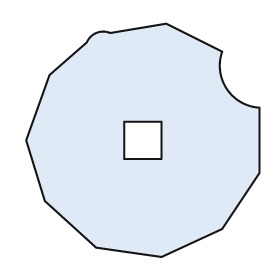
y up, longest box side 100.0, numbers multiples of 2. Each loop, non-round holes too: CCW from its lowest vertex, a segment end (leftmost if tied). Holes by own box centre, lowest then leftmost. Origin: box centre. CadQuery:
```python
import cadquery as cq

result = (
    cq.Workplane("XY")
    .moveTo(8.0, -50.0)
    .lineTo(34.0, -38.0)
    .lineTo(50.0, -14.0)
    .lineTo(50.0, 14.0)
    .threePointArc((36.0, 22.0), (34.0, 38.0))
    .lineTo(10.0, 50.0)
    .lineTo(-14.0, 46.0)
    .threePointArc((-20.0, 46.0), (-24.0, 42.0))
    .lineTo(-40.0, 28.0)
    .lineTo(-50.0, 0.0)
    .lineTo(-42.0, -26.0)
    .lineTo(-20.0, -46.0)
    .close()
    .moveTo(-8.0, -8.0)
    .lineTo(8.0, -8.0)
    .lineTo(8.0, 8.0)
    .lineTo(-8.0, 8.0)
    .close()
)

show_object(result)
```